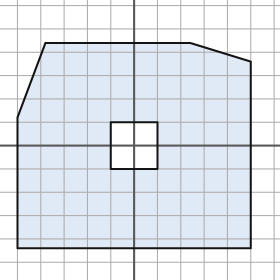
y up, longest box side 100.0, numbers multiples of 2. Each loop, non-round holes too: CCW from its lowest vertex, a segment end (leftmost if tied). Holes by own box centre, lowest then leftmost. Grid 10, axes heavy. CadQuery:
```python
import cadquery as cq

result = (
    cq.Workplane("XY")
    .moveTo(-50.0, -44.0)
    .lineTo(50.0, -44.0)
    .lineTo(50.0, 36.0)
    .lineTo(24.0, 44.0)
    .lineTo(-38.0, 44.0)
    .lineTo(-50.0, 12.0)
    .close()
    .moveTo(-10.0, -10.0)
    .lineTo(10.0, -10.0)
    .lineTo(10.0, 10.0)
    .lineTo(-10.0, 10.0)
    .close()
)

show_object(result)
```